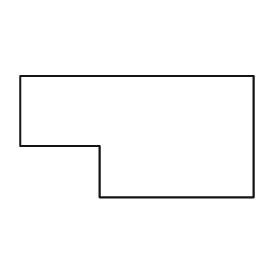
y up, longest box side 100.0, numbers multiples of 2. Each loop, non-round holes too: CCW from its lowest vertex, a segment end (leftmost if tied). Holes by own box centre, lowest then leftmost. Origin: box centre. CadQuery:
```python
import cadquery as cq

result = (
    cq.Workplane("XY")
    .moveTo(-16.0, -26.0)
    .lineTo(50.0, -26.0)
    .lineTo(50.0, 26.0)
    .lineTo(-50.0, 26.0)
    .lineTo(-50.0, -4.0)
    .lineTo(-16.0, -4.0)
    .close()
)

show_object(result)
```